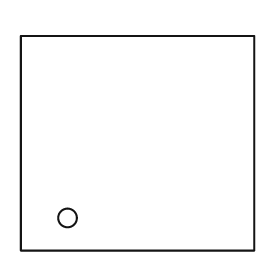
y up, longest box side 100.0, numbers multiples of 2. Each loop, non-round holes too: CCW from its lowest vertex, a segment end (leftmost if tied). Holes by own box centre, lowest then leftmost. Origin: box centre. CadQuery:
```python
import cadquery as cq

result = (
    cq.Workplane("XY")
    .moveTo(-50.0, -46.0)
    .lineTo(50.0, -46.0)
    .lineTo(50.0, 46.0)
    .lineTo(-50.0, 46.0)
    .close()
    .moveTo(-30.0, -32.0)
    .circle(4.0)
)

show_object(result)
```